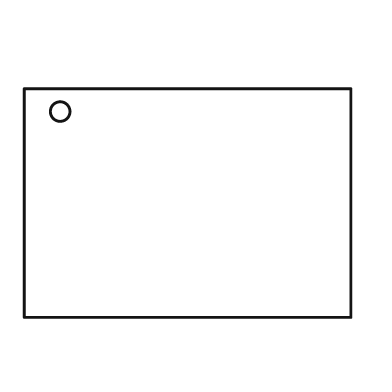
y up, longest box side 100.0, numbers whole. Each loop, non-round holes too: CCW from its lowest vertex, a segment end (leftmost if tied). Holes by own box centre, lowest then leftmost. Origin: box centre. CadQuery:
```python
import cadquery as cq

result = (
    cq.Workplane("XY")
    .moveTo(-50.0, -35.0)
    .lineTo(50.0, -35.0)
    .lineTo(50.0, 35.0)
    .lineTo(-50.0, 35.0)
    .close()
    .moveTo(-39.0, 28.0)
    .circle(3.0)
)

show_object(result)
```